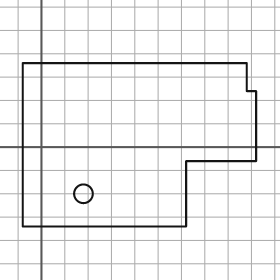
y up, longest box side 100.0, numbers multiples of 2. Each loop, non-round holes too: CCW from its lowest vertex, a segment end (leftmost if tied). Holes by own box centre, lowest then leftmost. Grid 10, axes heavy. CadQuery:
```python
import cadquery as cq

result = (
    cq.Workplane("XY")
    .moveTo(-8.0, -34.0)
    .lineTo(62.0, -34.0)
    .lineTo(62.0, -6.0)
    .lineTo(92.0, -6.0)
    .lineTo(92.0, 24.0)
    .lineTo(88.0, 24.0)
    .lineTo(88.0, 36.0)
    .lineTo(-8.0, 36.0)
    .close()
    .moveTo(18.0, -20.0)
    .circle(4.0)
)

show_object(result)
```